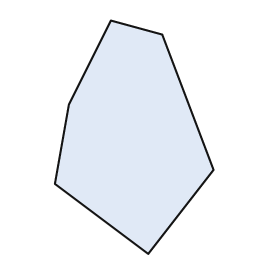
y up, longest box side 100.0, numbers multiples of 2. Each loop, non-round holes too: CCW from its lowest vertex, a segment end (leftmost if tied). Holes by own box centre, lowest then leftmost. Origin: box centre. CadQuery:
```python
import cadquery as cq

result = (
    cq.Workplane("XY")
    .moveTo(6.0, -50.0)
    .lineTo(34.0, -14.0)
    .lineTo(12.0, 44.0)
    .lineTo(-10.0, 50.0)
    .lineTo(-28.0, 14.0)
    .lineTo(-34.0, -20.0)
    .close()
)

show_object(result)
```